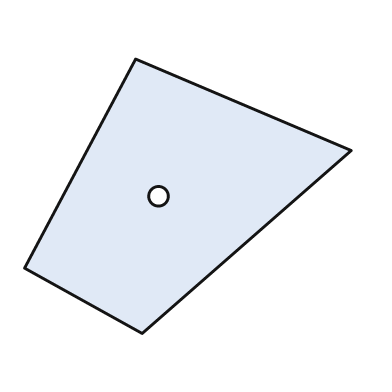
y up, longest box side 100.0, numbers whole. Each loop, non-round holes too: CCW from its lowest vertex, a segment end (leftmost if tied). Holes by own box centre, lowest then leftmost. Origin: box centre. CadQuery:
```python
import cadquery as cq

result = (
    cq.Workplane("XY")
    .moveTo(-14.0, -42.0)
    .lineTo(50.0, 14.0)
    .lineTo(-16.0, 42.0)
    .lineTo(-50.0, -22.0)
    .close()
    .moveTo(-9.0, 0.0)
    .circle(3.0)
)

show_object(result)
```